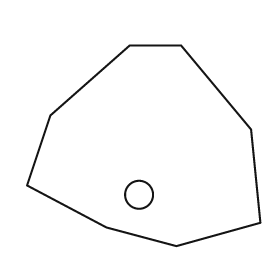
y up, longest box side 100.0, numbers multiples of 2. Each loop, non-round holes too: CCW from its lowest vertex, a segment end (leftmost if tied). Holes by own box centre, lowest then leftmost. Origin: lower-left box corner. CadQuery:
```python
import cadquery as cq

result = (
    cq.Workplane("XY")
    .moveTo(64.0, 0.0)
    .lineTo(100.0, 10.0)
    .lineTo(96.0, 50.0)
    .lineTo(66.0, 86.0)
    .lineTo(44.0, 86.0)
    .lineTo(10.0, 56.0)
    .lineTo(0.0, 26.0)
    .lineTo(34.0, 8.0)
    .close()
    .moveTo(48.0, 22.0)
    .circle(6.0)
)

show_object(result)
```